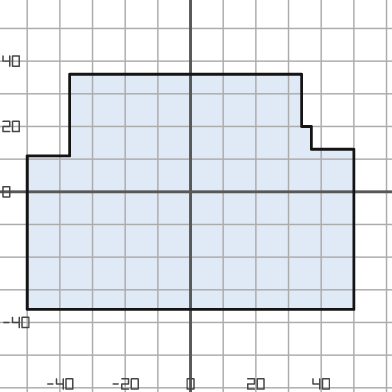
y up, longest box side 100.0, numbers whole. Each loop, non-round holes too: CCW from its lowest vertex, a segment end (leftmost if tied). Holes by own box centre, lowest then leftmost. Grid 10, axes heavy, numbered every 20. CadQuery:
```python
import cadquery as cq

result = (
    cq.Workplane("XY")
    .moveTo(-50.0, -36.0)
    .lineTo(50.0, -36.0)
    .lineTo(50.0, 13.0)
    .lineTo(37.0, 13.0)
    .lineTo(37.0, 20.0)
    .lineTo(34.0, 20.0)
    .lineTo(34.0, 36.0)
    .lineTo(-37.0, 36.0)
    .lineTo(-37.0, 11.0)
    .lineTo(-50.0, 11.0)
    .close()
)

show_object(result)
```